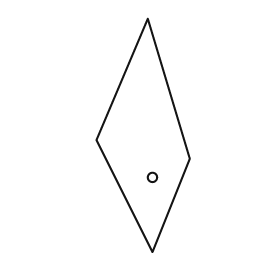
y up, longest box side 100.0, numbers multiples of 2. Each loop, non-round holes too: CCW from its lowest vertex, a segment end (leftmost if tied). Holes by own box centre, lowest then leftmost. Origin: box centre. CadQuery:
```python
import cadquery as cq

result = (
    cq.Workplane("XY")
    .moveTo(4.0, -50.0)
    .lineTo(20.0, -10.0)
    .lineTo(2.0, 50.0)
    .lineTo(-20.0, -2.0)
    .close()
    .moveTo(4.0, -18.0)
    .circle(2.0)
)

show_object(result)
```